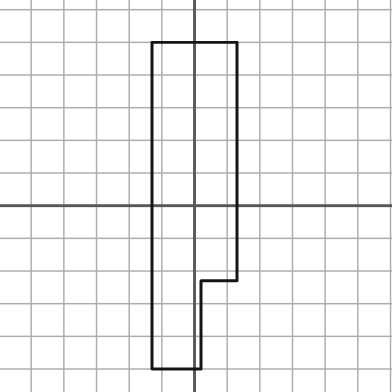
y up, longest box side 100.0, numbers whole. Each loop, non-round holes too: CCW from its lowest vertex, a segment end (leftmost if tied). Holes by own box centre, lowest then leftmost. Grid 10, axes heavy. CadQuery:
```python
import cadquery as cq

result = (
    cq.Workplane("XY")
    .moveTo(-13.0, -50.0)
    .lineTo(2.0, -50.0)
    .lineTo(2.0, -23.0)
    .lineTo(13.0, -23.0)
    .lineTo(13.0, 50.0)
    .lineTo(-13.0, 50.0)
    .close()
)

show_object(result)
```